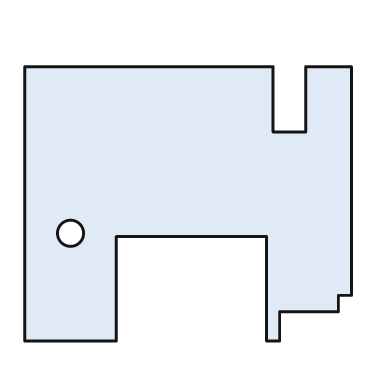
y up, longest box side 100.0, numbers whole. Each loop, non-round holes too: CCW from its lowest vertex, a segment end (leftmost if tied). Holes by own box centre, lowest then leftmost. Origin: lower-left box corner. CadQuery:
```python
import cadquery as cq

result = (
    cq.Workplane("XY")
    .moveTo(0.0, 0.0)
    .lineTo(28.0, 0.0)
    .lineTo(28.0, 32.0)
    .lineTo(74.0, 32.0)
    .lineTo(74.0, 0.0)
    .lineTo(78.0, 0.0)
    .lineTo(78.0, 9.0)
    .lineTo(96.0, 9.0)
    .lineTo(96.0, 14.0)
    .lineTo(100.0, 14.0)
    .lineTo(100.0, 84.0)
    .lineTo(86.0, 84.0)
    .lineTo(86.0, 64.0)
    .lineTo(76.0, 64.0)
    .lineTo(76.0, 84.0)
    .lineTo(0.0, 84.0)
    .close()
    .moveTo(14.0, 33.0)
    .circle(4.0)
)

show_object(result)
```